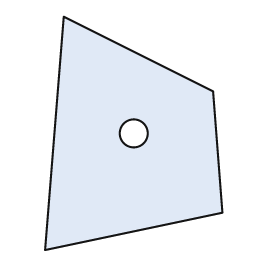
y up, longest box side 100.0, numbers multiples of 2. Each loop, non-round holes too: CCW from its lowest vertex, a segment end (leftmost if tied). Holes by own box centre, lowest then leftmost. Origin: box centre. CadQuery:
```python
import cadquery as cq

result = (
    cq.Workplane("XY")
    .moveTo(-38.0, -50.0)
    .lineTo(38.0, -34.0)
    .lineTo(34.0, 18.0)
    .lineTo(-30.0, 50.0)
    .close()
    .moveTo(0.0, 0.0)
    .circle(6.0)
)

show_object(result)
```